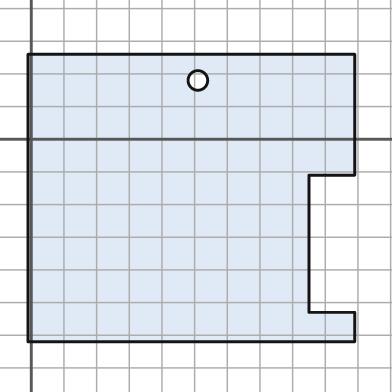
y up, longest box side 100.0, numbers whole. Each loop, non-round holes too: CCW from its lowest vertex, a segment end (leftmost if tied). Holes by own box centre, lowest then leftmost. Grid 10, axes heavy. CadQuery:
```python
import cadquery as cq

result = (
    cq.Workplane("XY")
    .moveTo(-1.0, -62.0)
    .lineTo(99.0, -62.0)
    .lineTo(99.0, -53.0)
    .lineTo(85.0, -53.0)
    .lineTo(85.0, -11.0)
    .lineTo(99.0, -11.0)
    .lineTo(99.0, 26.0)
    .lineTo(-1.0, 26.0)
    .close()
    .moveTo(51.0, 18.0)
    .circle(3.0)
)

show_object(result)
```